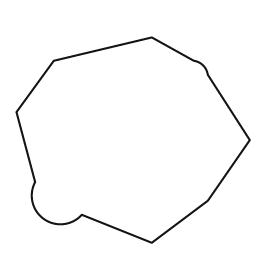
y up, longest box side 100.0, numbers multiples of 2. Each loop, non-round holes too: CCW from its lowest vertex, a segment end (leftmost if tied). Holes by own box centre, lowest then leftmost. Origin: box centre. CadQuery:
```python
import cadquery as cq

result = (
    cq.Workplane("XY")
    .moveTo(8.0, -44.0)
    .lineTo(32.0, -26.0)
    .lineTo(50.0, 0.0)
    .lineTo(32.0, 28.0)
    .threePointArc((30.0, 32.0), (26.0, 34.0))
    .lineTo(8.0, 44.0)
    .lineTo(-34.0, 34.0)
    .lineTo(-50.0, 12.0)
    .lineTo(-42.0, -18.0)
    .threePointArc((-38.0, -34.0), (-22.0, -32.0))
    .close()
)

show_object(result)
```